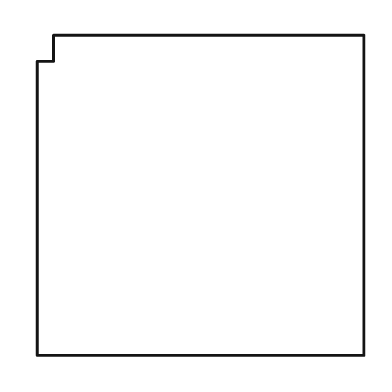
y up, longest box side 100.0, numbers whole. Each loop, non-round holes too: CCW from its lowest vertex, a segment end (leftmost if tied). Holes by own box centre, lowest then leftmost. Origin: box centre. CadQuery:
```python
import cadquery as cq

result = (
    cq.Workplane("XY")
    .moveTo(-50.0, -49.0)
    .lineTo(50.0, -49.0)
    .lineTo(50.0, 49.0)
    .lineTo(-45.0, 49.0)
    .lineTo(-45.0, 41.0)
    .lineTo(-50.0, 41.0)
    .close()
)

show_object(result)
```